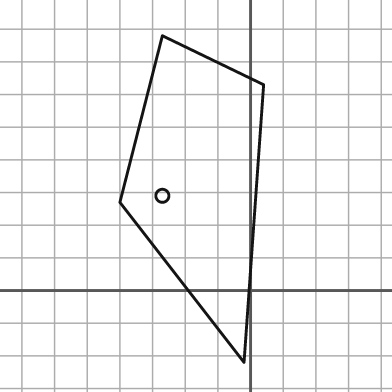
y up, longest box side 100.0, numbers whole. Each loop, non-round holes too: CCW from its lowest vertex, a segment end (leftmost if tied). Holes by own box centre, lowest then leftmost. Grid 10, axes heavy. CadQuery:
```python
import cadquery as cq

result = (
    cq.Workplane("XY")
    .moveTo(-2.0, -22.0)
    .lineTo(4.0, 63.0)
    .lineTo(-27.0, 78.0)
    .lineTo(-40.0, 27.0)
    .close()
    .moveTo(-27.0, 29.0)
    .circle(2.0)
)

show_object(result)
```